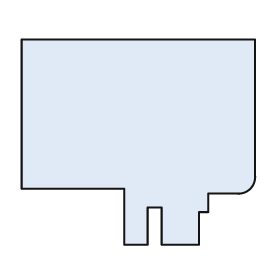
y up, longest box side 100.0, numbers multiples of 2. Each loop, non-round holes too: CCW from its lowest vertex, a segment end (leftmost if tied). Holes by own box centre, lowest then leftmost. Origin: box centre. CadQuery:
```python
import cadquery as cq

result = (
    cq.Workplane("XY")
    .moveTo(-6.0, -44.0)
    .lineTo(4.0, -44.0)
    .lineTo(4.0, -28.0)
    .lineTo(10.0, -28.0)
    .lineTo(10.0, -44.0)
    .lineTo(26.0, -44.0)
    .lineTo(26.0, -30.0)
    .lineTo(30.0, -30.0)
    .lineTo(30.0, -22.0)
    .lineTo(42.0, -22.0)
    .threePointArc((48.0, -20.0), (50.0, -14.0))
    .lineTo(50.0, 44.0)
    .lineTo(-50.0, 44.0)
    .lineTo(-50.0, -20.0)
    .lineTo(-6.0, -20.0)
    .close()
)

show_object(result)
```